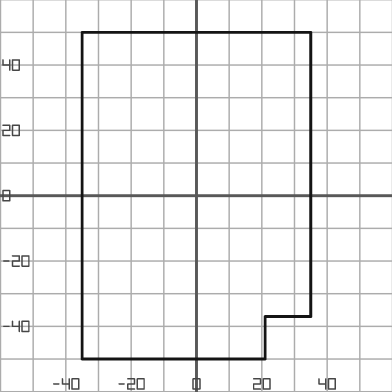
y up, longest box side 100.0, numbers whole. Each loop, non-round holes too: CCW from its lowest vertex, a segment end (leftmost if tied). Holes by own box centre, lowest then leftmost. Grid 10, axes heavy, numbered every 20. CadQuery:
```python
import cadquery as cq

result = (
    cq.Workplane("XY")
    .moveTo(-35.0, -50.0)
    .lineTo(21.0, -50.0)
    .lineTo(21.0, -37.0)
    .lineTo(35.0, -37.0)
    .lineTo(35.0, 50.0)
    .lineTo(-35.0, 50.0)
    .close()
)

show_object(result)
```